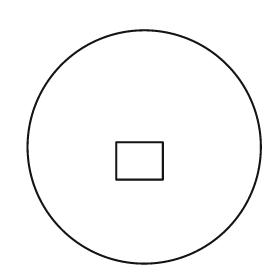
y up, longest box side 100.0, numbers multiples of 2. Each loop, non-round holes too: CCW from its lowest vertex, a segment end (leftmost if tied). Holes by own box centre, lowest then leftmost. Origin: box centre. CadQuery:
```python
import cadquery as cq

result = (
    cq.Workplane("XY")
    .moveTo(0.0, 0.0)
    .circle(50.0)
    .moveTo(-12.0, -14.0)
    .lineTo(8.0, -14.0)
    .lineTo(8.0, 2.0)
    .lineTo(-12.0, 2.0)
    .close()
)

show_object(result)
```